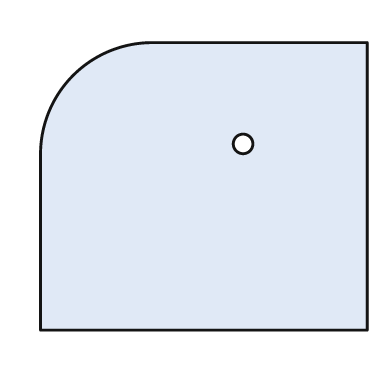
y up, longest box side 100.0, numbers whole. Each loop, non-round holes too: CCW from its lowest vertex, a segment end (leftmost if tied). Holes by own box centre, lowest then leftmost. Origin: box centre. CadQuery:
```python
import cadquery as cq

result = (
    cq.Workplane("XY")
    .moveTo(-50.0, -44.0)
    .lineTo(50.0, -44.0)
    .lineTo(50.0, 44.0)
    .lineTo(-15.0, 44.0)
    .threePointArc((-40.0, 34.0), (-50.0, 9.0))
    .close()
    .moveTo(12.0, 13.0)
    .circle(3.0)
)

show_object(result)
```